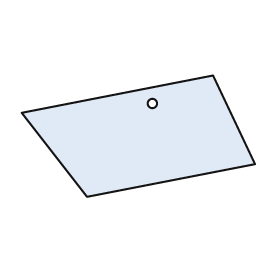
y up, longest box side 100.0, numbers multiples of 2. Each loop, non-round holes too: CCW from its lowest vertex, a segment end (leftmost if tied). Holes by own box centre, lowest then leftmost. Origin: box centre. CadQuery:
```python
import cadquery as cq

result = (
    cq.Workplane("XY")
    .moveTo(-22.0, -26.0)
    .lineTo(50.0, -12.0)
    .lineTo(32.0, 26.0)
    .lineTo(-50.0, 10.0)
    .close()
    .moveTo(6.0, 14.0)
    .circle(2.0)
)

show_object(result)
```